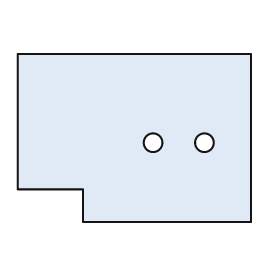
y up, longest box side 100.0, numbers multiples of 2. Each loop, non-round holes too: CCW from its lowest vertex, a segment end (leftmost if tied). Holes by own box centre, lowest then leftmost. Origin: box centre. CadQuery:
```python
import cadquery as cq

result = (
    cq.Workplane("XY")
    .moveTo(-22.0, -36.0)
    .lineTo(50.0, -36.0)
    .lineTo(50.0, 36.0)
    .lineTo(-50.0, 36.0)
    .lineTo(-50.0, -22.0)
    .lineTo(-22.0, -22.0)
    .close()
    .moveTo(8.0, -2.0)
    .circle(4.0)
    .moveTo(30.0, -2.0)
    .circle(4.0)
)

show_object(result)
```